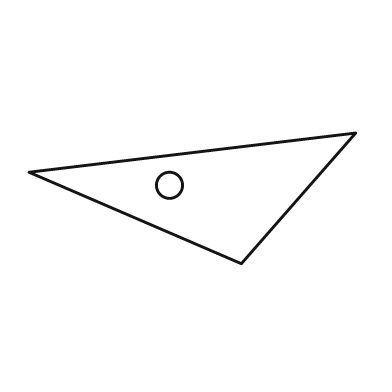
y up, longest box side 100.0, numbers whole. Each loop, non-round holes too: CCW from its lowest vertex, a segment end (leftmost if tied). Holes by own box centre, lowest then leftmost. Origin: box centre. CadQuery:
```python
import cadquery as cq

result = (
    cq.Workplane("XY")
    .moveTo(15.0, -20.0)
    .lineTo(50.0, 20.0)
    .lineTo(-50.0, 8.0)
    .close()
    .moveTo(-7.0, 4.0)
    .circle(4.0)
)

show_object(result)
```